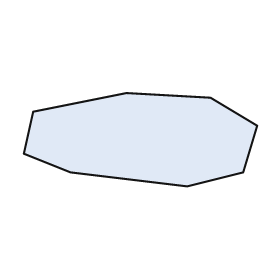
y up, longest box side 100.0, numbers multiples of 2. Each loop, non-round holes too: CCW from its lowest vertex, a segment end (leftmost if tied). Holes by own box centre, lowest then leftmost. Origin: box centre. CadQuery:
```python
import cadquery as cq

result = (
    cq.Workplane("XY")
    .moveTo(20.0, -20.0)
    .lineTo(44.0, -14.0)
    .lineTo(50.0, 6.0)
    .lineTo(30.0, 18.0)
    .lineTo(-6.0, 20.0)
    .lineTo(-46.0, 12.0)
    .lineTo(-50.0, -6.0)
    .lineTo(-30.0, -14.0)
    .close()
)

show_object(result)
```